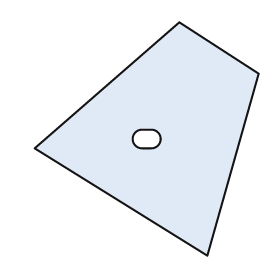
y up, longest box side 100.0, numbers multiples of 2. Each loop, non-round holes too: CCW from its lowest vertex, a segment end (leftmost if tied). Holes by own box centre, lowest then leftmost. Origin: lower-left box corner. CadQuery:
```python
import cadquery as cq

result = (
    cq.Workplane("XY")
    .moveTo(74.0, 0.0)
    .lineTo(96.0, 78.0)
    .lineTo(62.0, 100.0)
    .lineTo(0.0, 46.0)
    .close()
    .moveTo(46.0, 46.0)
    .lineTo(50.0, 46.0)
    .threePointArc((54.0, 50.0), (50.0, 54.0))
    .lineTo(46.0, 54.0)
    .threePointArc((42.0, 50.0), (46.0, 46.0))
    .close()
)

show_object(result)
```